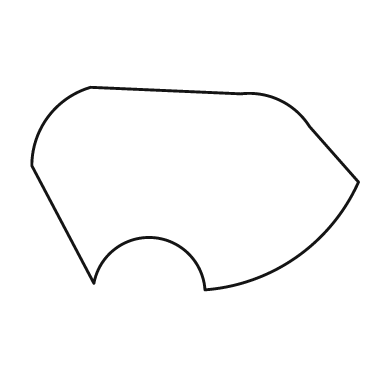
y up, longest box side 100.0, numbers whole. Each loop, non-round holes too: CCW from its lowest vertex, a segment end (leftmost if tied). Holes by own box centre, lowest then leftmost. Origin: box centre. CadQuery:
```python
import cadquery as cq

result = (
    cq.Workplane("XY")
    .moveTo(3.0, -31.0)
    .threePointArc((31.0, -21.0), (50.0, 2.0))
    .lineTo(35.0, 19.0)
    .threePointArc((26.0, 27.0), (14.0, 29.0))
    .lineTo(-32.0, 31.0)
    .threePointArc((-45.0, 22.0), (-50.0, 7.0))
    .lineTo(-31.0, -29.0)
    .threePointArc((-13.0, -15.0), (3.0, -31.0))
    .close()
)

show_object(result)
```